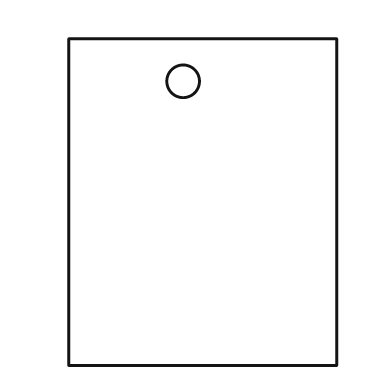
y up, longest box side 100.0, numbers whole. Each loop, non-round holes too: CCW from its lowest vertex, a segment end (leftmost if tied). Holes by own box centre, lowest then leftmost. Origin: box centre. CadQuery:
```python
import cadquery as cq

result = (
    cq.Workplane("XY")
    .moveTo(-41.0, -50.0)
    .lineTo(41.0, -50.0)
    .lineTo(41.0, 50.0)
    .lineTo(-41.0, 50.0)
    .close()
    .moveTo(-6.0, 37.0)
    .circle(5.0)
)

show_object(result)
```